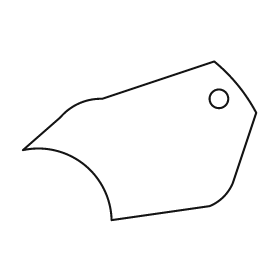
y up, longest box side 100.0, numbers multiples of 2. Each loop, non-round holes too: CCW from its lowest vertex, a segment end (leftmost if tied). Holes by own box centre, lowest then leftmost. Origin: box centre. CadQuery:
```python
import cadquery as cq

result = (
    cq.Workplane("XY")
    .moveTo(-12.0, -34.0)
    .lineTo(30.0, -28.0)
    .threePointArc((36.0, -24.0), (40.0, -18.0))
    .lineTo(50.0, 12.0)
    .threePointArc((42.0, 24.0), (32.0, 34.0))
    .lineTo(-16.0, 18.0)
    .threePointArc((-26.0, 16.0), (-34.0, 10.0))
    .lineTo(-50.0, -4.0)
    .threePointArc((-24.0, -10.0), (-12.0, -34.0))
    .close()
    .moveTo(34.0, 18.0)
    .circle(4.0)
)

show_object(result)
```